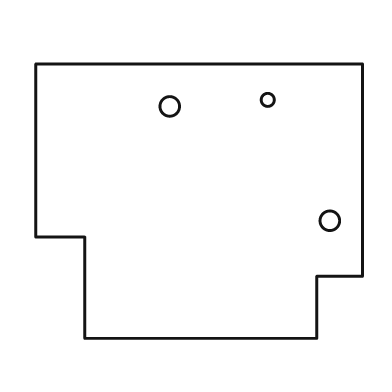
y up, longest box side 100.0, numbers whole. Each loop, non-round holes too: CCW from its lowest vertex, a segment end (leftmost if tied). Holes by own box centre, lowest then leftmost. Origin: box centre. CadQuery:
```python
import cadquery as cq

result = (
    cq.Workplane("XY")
    .moveTo(-35.0, -42.0)
    .lineTo(36.0, -42.0)
    .lineTo(36.0, -23.0)
    .lineTo(50.0, -23.0)
    .lineTo(50.0, 42.0)
    .lineTo(-50.0, 42.0)
    .lineTo(-50.0, -11.0)
    .lineTo(-35.0, -11.0)
    .close()
    .moveTo(40.0, -6.0)
    .circle(3.0)
    .moveTo(-9.0, 29.0)
    .circle(3.0)
    .moveTo(21.0, 31.0)
    .circle(2.0)
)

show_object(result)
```